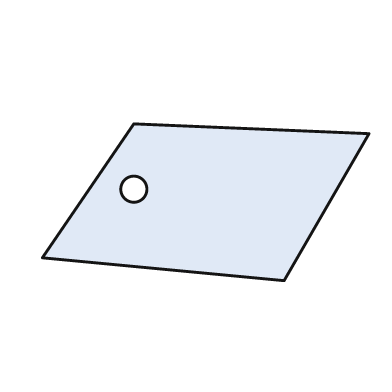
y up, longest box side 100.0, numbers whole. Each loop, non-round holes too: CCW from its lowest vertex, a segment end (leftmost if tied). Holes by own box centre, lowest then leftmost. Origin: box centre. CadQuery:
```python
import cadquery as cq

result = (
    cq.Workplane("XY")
    .moveTo(24.0, -24.0)
    .lineTo(50.0, 21.0)
    .lineTo(-22.0, 24.0)
    .lineTo(-50.0, -17.0)
    .close()
    .moveTo(-22.0, 4.0)
    .circle(4.0)
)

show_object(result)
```